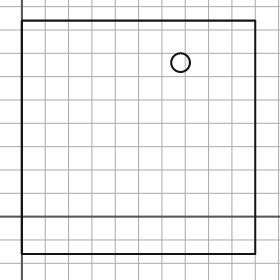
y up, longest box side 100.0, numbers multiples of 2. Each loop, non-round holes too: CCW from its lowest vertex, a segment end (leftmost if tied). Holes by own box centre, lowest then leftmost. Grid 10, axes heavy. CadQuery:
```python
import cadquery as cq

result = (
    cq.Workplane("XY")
    .moveTo(0.0, -16.0)
    .lineTo(100.0, -16.0)
    .lineTo(100.0, 84.0)
    .lineTo(0.0, 84.0)
    .close()
    .moveTo(68.0, 66.0)
    .circle(4.0)
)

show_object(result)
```